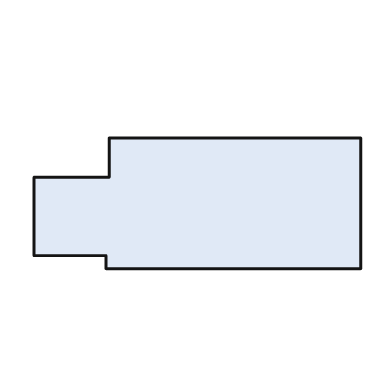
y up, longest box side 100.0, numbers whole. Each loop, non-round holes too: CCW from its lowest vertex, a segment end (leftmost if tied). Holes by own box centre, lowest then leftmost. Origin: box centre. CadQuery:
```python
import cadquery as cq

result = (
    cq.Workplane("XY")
    .moveTo(-28.0, -20.0)
    .lineTo(50.0, -20.0)
    .lineTo(50.0, 20.0)
    .lineTo(-27.0, 20.0)
    .lineTo(-27.0, 8.0)
    .lineTo(-50.0, 8.0)
    .lineTo(-50.0, -16.0)
    .lineTo(-28.0, -16.0)
    .close()
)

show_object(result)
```